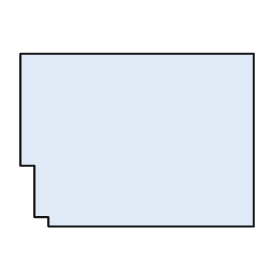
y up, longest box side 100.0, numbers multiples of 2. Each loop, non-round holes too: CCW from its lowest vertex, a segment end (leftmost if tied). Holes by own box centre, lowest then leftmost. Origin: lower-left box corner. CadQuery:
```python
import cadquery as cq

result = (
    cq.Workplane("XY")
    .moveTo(12.0, 0.0)
    .lineTo(100.0, 0.0)
    .lineTo(100.0, 74.0)
    .lineTo(0.0, 74.0)
    .lineTo(0.0, 26.0)
    .lineTo(6.0, 26.0)
    .lineTo(6.0, 4.0)
    .lineTo(12.0, 4.0)
    .close()
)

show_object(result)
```